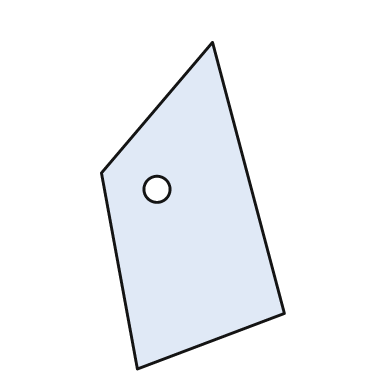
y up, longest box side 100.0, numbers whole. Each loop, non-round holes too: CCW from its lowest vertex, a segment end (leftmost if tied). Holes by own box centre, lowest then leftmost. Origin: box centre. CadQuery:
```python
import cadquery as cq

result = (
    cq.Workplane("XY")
    .moveTo(-17.0, -50.0)
    .lineTo(28.0, -33.0)
    .lineTo(6.0, 50.0)
    .lineTo(-28.0, 10.0)
    .close()
    .moveTo(-11.0, 5.0)
    .circle(4.0)
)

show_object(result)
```